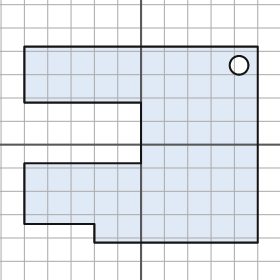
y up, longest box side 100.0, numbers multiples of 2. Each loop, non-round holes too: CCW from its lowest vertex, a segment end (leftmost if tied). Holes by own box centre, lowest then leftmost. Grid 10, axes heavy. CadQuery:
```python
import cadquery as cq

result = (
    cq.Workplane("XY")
    .moveTo(-20.0, -42.0)
    .lineTo(50.0, -42.0)
    .lineTo(50.0, 42.0)
    .lineTo(-50.0, 42.0)
    .lineTo(-50.0, 18.0)
    .lineTo(0.0, 18.0)
    .lineTo(0.0, -8.0)
    .lineTo(-50.0, -8.0)
    .lineTo(-50.0, -34.0)
    .lineTo(-20.0, -34.0)
    .close()
    .moveTo(42.0, 34.0)
    .circle(4.0)
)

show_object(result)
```